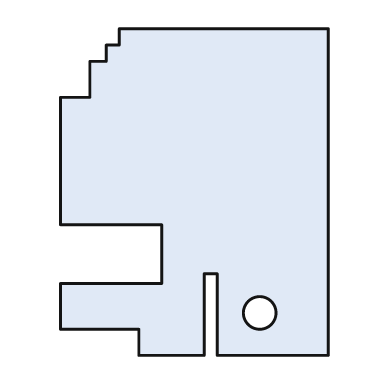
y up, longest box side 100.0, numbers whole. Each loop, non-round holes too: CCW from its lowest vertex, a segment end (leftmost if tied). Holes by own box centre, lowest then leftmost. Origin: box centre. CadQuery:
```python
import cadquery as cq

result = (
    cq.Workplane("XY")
    .moveTo(-17.0, -50.0)
    .lineTo(3.0, -50.0)
    .lineTo(3.0, -25.0)
    .lineTo(7.0, -25.0)
    .lineTo(7.0, -50.0)
    .lineTo(41.0, -50.0)
    .lineTo(41.0, 50.0)
    .lineTo(-23.0, 50.0)
    .lineTo(-23.0, 45.0)
    .lineTo(-27.0, 45.0)
    .lineTo(-27.0, 40.0)
    .lineTo(-32.0, 40.0)
    .lineTo(-32.0, 29.0)
    .lineTo(-41.0, 29.0)
    .lineTo(-41.0, -10.0)
    .lineTo(-10.0, -10.0)
    .lineTo(-10.0, -28.0)
    .lineTo(-41.0, -28.0)
    .lineTo(-41.0, -42.0)
    .lineTo(-17.0, -42.0)
    .close()
    .moveTo(20.0, -37.0)
    .circle(5.0)
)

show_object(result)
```